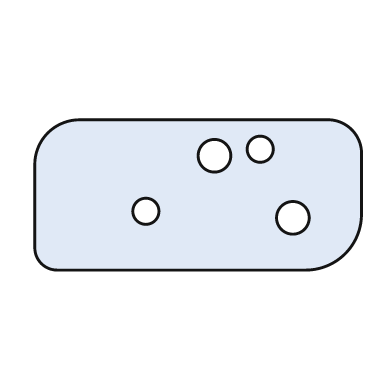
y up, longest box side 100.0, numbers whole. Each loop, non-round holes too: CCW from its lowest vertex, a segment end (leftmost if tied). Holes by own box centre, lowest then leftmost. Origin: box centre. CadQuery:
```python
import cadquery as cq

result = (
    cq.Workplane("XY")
    .moveTo(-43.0, -23.0)
    .lineTo(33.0, -23.0)
    .threePointArc((45.0, -18.0), (50.0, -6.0))
    .lineTo(50.0, 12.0)
    .threePointArc((47.0, 20.0), (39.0, 23.0))
    .lineTo(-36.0, 23.0)
    .threePointArc((-46.0, 19.0), (-50.0, 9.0))
    .lineTo(-50.0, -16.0)
    .threePointArc((-48.0, -21.0), (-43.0, -23.0))
    .close()
    .moveTo(29.0, -7.0)
    .circle(5.0)
    .moveTo(-16.0, -5.0)
    .circle(4.0)
    .moveTo(5.0, 12.0)
    .circle(5.0)
    .moveTo(19.0, 14.0)
    .circle(4.0)
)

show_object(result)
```